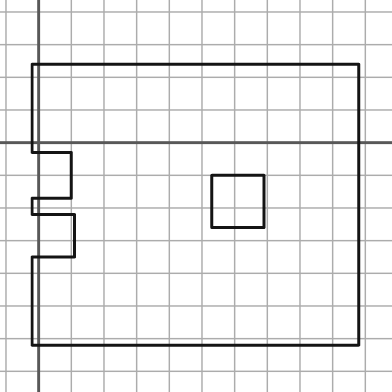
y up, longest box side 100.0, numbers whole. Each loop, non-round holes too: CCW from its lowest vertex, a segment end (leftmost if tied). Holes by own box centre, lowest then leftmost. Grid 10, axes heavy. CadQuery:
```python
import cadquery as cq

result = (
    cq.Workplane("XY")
    .moveTo(-2.0, -62.0)
    .lineTo(98.0, -62.0)
    .lineTo(98.0, 24.0)
    .lineTo(-2.0, 24.0)
    .lineTo(-2.0, -3.0)
    .lineTo(10.0, -3.0)
    .lineTo(10.0, -17.0)
    .lineTo(-2.0, -17.0)
    .lineTo(-2.0, -22.0)
    .lineTo(11.0, -22.0)
    .lineTo(11.0, -35.0)
    .lineTo(-2.0, -35.0)
    .close()
    .moveTo(53.0, -26.0)
    .lineTo(69.0, -26.0)
    .lineTo(69.0, -10.0)
    .lineTo(53.0, -10.0)
    .close()
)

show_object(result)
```